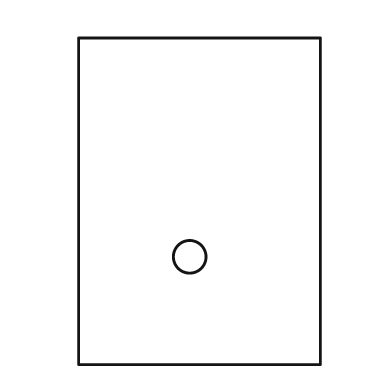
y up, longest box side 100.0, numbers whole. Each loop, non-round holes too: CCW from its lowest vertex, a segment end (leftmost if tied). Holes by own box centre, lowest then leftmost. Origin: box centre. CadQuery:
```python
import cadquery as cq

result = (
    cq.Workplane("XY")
    .moveTo(-37.0, -50.0)
    .lineTo(37.0, -50.0)
    .lineTo(37.0, 50.0)
    .lineTo(-37.0, 50.0)
    .close()
    .moveTo(-3.0, -17.0)
    .circle(5.0)
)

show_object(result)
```